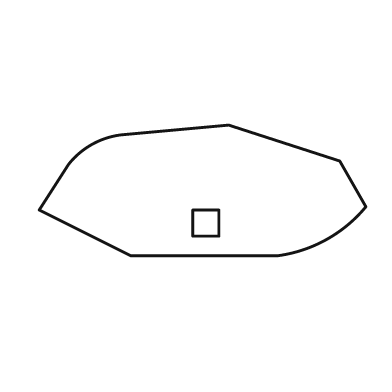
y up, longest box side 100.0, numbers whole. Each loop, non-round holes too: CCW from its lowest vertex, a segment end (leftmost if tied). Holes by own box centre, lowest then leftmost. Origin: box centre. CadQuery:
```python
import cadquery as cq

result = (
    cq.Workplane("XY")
    .moveTo(-22.0, -20.0)
    .lineTo(23.0, -20.0)
    .threePointArc((38.0, -15.0), (50.0, -5.0))
    .lineTo(42.0, 9.0)
    .lineTo(8.0, 20.0)
    .lineTo(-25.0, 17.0)
    .threePointArc((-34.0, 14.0), (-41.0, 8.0))
    .lineTo(-50.0, -6.0)
    .close()
    .moveTo(-3.0, -14.0)
    .lineTo(5.0, -14.0)
    .lineTo(5.0, -6.0)
    .lineTo(-3.0, -6.0)
    .close()
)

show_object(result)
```